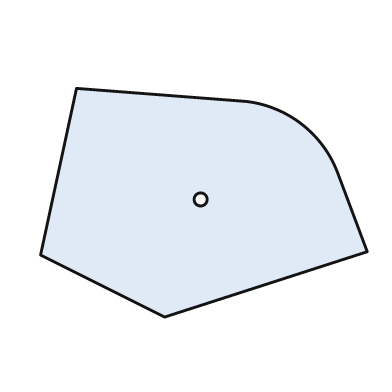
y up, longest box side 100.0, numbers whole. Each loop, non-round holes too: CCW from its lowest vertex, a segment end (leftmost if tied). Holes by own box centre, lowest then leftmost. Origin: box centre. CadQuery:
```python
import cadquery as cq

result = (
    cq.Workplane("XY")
    .moveTo(-12.0, -35.0)
    .lineTo(50.0, -15.0)
    .lineTo(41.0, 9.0)
    .threePointArc((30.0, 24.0), (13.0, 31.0))
    .lineTo(-39.0, 35.0)
    .lineTo(-50.0, -16.0)
    .close()
    .moveTo(-1.0, 1.0)
    .circle(2.0)
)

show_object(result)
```